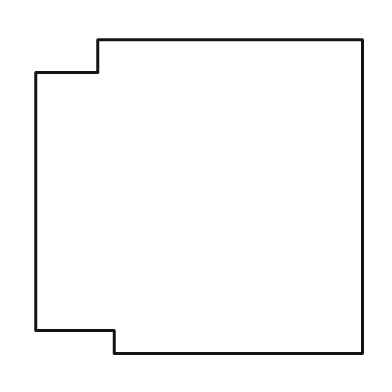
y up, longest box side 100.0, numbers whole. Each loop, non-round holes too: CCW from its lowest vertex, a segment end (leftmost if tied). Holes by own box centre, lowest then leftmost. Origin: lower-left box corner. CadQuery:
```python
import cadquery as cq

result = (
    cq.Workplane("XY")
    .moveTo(24.0, 0.0)
    .lineTo(100.0, 0.0)
    .lineTo(100.0, 96.0)
    .lineTo(19.0, 96.0)
    .lineTo(19.0, 86.0)
    .lineTo(0.0, 86.0)
    .lineTo(0.0, 7.0)
    .lineTo(24.0, 7.0)
    .close()
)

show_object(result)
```